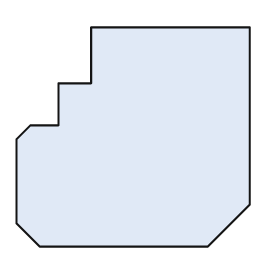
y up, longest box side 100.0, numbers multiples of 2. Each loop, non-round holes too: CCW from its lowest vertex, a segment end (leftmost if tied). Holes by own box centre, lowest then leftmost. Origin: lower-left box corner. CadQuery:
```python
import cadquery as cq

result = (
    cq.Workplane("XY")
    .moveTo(10.0, 0.0)
    .lineTo(82.0, 0.0)
    .lineTo(100.0, 18.0)
    .lineTo(100.0, 94.0)
    .lineTo(32.0, 94.0)
    .lineTo(32.0, 70.0)
    .lineTo(18.0, 70.0)
    .lineTo(18.0, 52.0)
    .lineTo(6.0, 52.0)
    .lineTo(0.0, 46.0)
    .lineTo(0.0, 10.0)
    .close()
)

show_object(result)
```